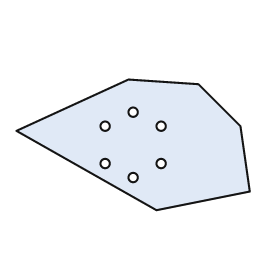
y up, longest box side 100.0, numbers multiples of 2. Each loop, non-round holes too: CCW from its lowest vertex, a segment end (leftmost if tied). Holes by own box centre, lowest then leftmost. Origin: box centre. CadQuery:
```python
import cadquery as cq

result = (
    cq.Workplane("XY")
    .moveTo(10.0, -28.0)
    .lineTo(50.0, -20.0)
    .lineTo(46.0, 8.0)
    .lineTo(28.0, 26.0)
    .lineTo(-2.0, 28.0)
    .lineTo(-50.0, 6.0)
    .close()
    .moveTo(0.0, -14.0)
    .circle(2.0)
    .moveTo(-12.0, -8.0)
    .circle(2.0)
    .moveTo(12.0, -8.0)
    .circle(2.0)
    .moveTo(-12.0, 8.0)
    .circle(2.0)
    .moveTo(12.0, 8.0)
    .circle(2.0)
    .moveTo(0.0, 14.0)
    .circle(2.0)
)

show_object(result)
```